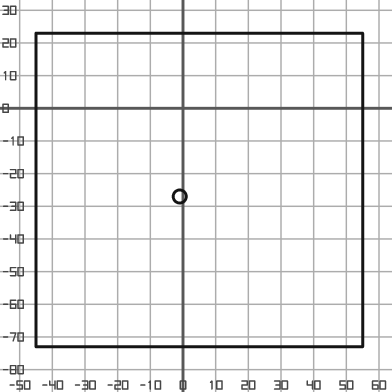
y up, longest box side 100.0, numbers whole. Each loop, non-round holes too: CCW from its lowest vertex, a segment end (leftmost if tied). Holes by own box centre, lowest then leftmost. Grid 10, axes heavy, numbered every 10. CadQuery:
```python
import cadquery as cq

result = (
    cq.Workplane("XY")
    .moveTo(-45.0, -73.0)
    .lineTo(55.0, -73.0)
    .lineTo(55.0, 23.0)
    .lineTo(-45.0, 23.0)
    .close()
    .moveTo(-1.0, -27.0)
    .circle(2.0)
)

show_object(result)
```